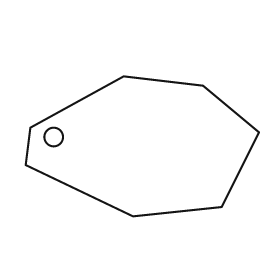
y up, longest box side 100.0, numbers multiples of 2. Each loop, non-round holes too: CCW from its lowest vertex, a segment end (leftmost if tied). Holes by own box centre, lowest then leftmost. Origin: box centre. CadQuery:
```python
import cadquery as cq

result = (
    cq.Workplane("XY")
    .moveTo(-4.0, -30.0)
    .lineTo(34.0, -26.0)
    .lineTo(50.0, 6.0)
    .lineTo(26.0, 26.0)
    .lineTo(-8.0, 30.0)
    .lineTo(-48.0, 8.0)
    .lineTo(-50.0, -8.0)
    .close()
    .moveTo(-38.0, 4.0)
    .circle(4.0)
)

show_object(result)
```